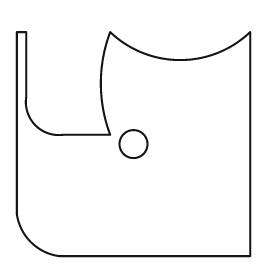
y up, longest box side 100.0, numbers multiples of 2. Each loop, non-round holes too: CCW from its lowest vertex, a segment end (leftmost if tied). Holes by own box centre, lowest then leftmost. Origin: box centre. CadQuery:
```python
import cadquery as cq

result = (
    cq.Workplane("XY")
    .moveTo(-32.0, -48.0)
    .lineTo(50.0, -48.0)
    .lineTo(50.0, 48.0)
    .threePointArc((20.0, 36.0), (-10.0, 48.0))
    .threePointArc((-14.0, 26.0), (-10.0, 4.0))
    .lineTo(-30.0, 4.0)
    .threePointArc((-42.0, 8.0), (-46.0, 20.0))
    .lineTo(-46.0, 48.0)
    .lineTo(-50.0, 48.0)
    .lineTo(-50.0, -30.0)
    .threePointArc((-44.0, -42.0), (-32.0, -48.0))
    .close()
    .moveTo(0.0, 0.0)
    .circle(6.0)
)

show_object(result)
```